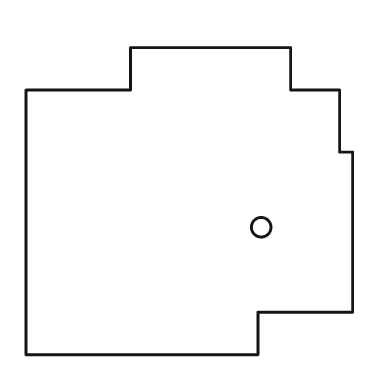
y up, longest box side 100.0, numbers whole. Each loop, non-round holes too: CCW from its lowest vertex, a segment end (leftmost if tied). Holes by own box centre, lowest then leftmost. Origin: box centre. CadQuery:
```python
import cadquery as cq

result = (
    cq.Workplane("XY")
    .moveTo(-50.0, -47.0)
    .lineTo(21.0, -47.0)
    .lineTo(21.0, -34.0)
    .lineTo(50.0, -34.0)
    .lineTo(50.0, 15.0)
    .lineTo(46.0, 15.0)
    .lineTo(46.0, 34.0)
    .lineTo(31.0, 34.0)
    .lineTo(31.0, 47.0)
    .lineTo(-18.0, 47.0)
    .lineTo(-18.0, 34.0)
    .lineTo(-50.0, 34.0)
    .close()
    .moveTo(22.0, -8.0)
    .circle(3.0)
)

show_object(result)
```